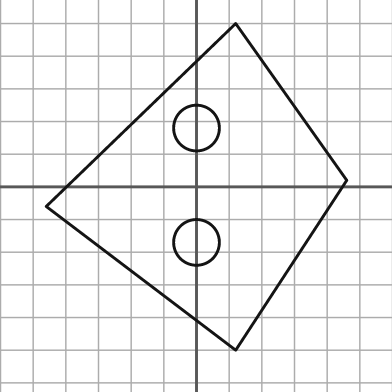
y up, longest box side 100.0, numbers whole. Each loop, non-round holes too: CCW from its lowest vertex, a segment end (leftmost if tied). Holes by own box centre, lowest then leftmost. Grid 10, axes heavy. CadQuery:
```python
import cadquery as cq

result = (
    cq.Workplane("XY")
    .moveTo(12.0, -50.0)
    .lineTo(46.0, 2.0)
    .lineTo(12.0, 50.0)
    .lineTo(-46.0, -6.0)
    .close()
    .moveTo(0.0, -17.0)
    .circle(7.0)
    .moveTo(0.0, 18.0)
    .circle(7.0)
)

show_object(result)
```